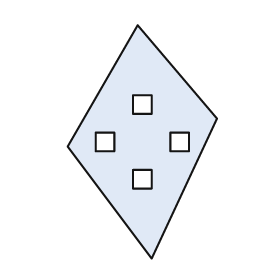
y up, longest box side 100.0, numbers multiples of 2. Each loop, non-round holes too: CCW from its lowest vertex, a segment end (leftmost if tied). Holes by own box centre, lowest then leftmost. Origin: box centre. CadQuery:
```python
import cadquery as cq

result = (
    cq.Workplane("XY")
    .moveTo(4.0, -50.0)
    .lineTo(32.0, 10.0)
    .lineTo(-2.0, 50.0)
    .lineTo(-32.0, -2.0)
    .close()
    .moveTo(-4.0, -20.0)
    .lineTo(4.0, -20.0)
    .lineTo(4.0, -12.0)
    .lineTo(-4.0, -12.0)
    .close()
    .moveTo(-20.0, -4.0)
    .lineTo(-12.0, -4.0)
    .lineTo(-12.0, 4.0)
    .lineTo(-20.0, 4.0)
    .close()
    .moveTo(12.0, -4.0)
    .lineTo(20.0, -4.0)
    .lineTo(20.0, 4.0)
    .lineTo(12.0, 4.0)
    .close()
    .moveTo(-4.0, 12.0)
    .lineTo(4.0, 12.0)
    .lineTo(4.0, 20.0)
    .lineTo(-4.0, 20.0)
    .close()
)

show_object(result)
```